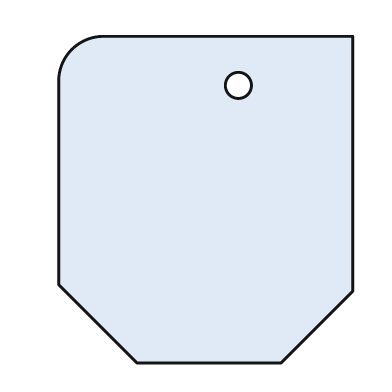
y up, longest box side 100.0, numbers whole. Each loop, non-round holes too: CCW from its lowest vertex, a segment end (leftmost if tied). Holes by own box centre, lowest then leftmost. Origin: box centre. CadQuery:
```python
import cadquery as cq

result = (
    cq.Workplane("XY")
    .moveTo(-21.0, -50.0)
    .lineTo(23.0, -50.0)
    .lineTo(45.0, -28.0)
    .lineTo(45.0, 50.0)
    .lineTo(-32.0, 50.0)
    .threePointArc((-41.0, 46.0), (-45.0, 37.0))
    .lineTo(-45.0, -26.0)
    .close()
    .moveTo(10.0, 35.0)
    .circle(4.0)
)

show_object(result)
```